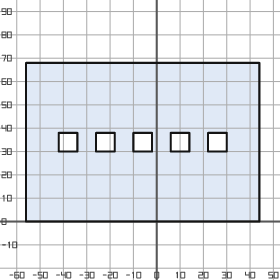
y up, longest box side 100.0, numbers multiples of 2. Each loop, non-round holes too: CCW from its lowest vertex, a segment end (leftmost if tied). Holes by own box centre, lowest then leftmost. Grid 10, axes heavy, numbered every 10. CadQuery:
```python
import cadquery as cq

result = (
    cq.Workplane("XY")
    .moveTo(-56.0, 0.0)
    .lineTo(44.0, 0.0)
    .lineTo(44.0, 68.0)
    .lineTo(-56.0, 68.0)
    .close()
    .moveTo(-42.0, 30.0)
    .lineTo(-34.0, 30.0)
    .lineTo(-34.0, 38.0)
    .lineTo(-42.0, 38.0)
    .close()
    .moveTo(-26.0, 30.0)
    .lineTo(-18.0, 30.0)
    .lineTo(-18.0, 38.0)
    .lineTo(-26.0, 38.0)
    .close()
    .moveTo(-10.0, 30.0)
    .lineTo(-2.0, 30.0)
    .lineTo(-2.0, 38.0)
    .lineTo(-10.0, 38.0)
    .close()
    .moveTo(6.0, 30.0)
    .lineTo(14.0, 30.0)
    .lineTo(14.0, 38.0)
    .lineTo(6.0, 38.0)
    .close()
    .moveTo(22.0, 30.0)
    .lineTo(30.0, 30.0)
    .lineTo(30.0, 38.0)
    .lineTo(22.0, 38.0)
    .close()
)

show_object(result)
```